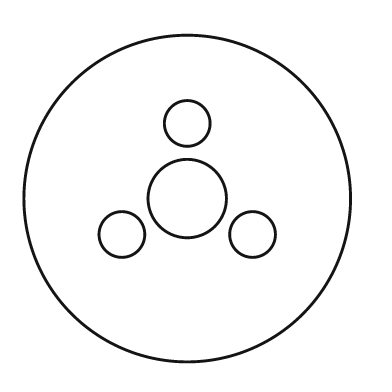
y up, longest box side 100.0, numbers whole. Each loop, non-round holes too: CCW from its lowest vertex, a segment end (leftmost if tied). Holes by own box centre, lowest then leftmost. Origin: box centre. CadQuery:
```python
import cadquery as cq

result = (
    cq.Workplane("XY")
    .moveTo(0.0, 0.0)
    .circle(50.0)
    .moveTo(-20.0, -11.0)
    .circle(7.0)
    .moveTo(20.0, -11.0)
    .circle(7.0)
    .moveTo(0.0, 0.0)
    .circle(12.0)
    .moveTo(0.0, 23.0)
    .circle(7.0)
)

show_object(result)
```